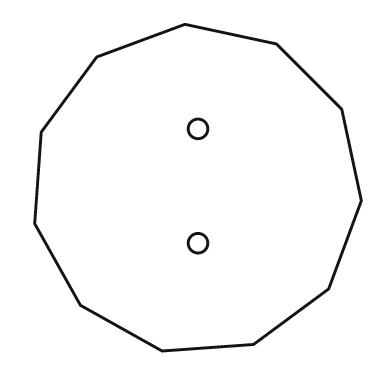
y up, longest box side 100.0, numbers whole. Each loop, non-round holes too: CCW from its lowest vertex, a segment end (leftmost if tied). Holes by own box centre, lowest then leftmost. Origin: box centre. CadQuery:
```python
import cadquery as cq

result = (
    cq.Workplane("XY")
    .moveTo(-11.0, -50.0)
    .lineTo(17.0, -48.0)
    .lineTo(40.0, -31.0)
    .lineTo(50.0, -4.0)
    .lineTo(44.0, 24.0)
    .lineTo(24.0, 44.0)
    .lineTo(-4.0, 50.0)
    .lineTo(-31.0, 40.0)
    .lineTo(-48.0, 17.0)
    .lineTo(-50.0, -11.0)
    .lineTo(-36.0, -36.0)
    .close()
    .moveTo(0.0, -17.0)
    .circle(3.0)
    .moveTo(0.0, 18.0)
    .circle(3.0)
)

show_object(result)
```